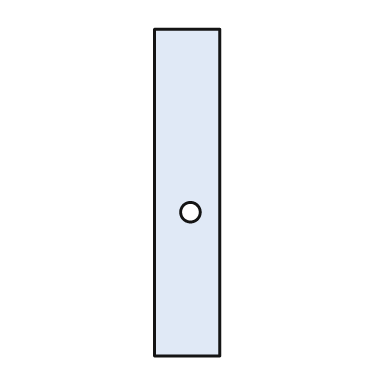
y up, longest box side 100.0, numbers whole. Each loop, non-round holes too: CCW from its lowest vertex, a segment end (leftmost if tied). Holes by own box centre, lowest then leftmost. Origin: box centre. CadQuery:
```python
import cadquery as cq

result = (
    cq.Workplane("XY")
    .moveTo(-10.0, -50.0)
    .lineTo(10.0, -50.0)
    .lineTo(10.0, 50.0)
    .lineTo(-10.0, 50.0)
    .close()
    .moveTo(1.0, -6.0)
    .circle(3.0)
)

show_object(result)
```